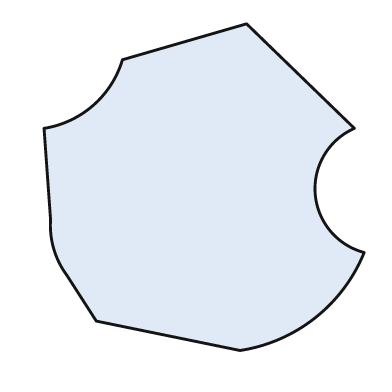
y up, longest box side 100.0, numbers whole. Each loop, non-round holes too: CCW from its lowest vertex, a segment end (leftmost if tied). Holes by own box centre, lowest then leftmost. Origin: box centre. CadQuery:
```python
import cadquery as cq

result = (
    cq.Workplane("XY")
    .moveTo(11.0, -50.0)
    .threePointArc((34.0, -40.0), (49.0, -20.0))
    .threePointArc((34.0, -2.0), (46.0, 18.0))
    .lineTo(13.0, 50.0)
    .lineTo(-25.0, 39.0)
    .threePointArc((-34.0, 25.0), (-49.0, 18.0))
    .lineTo(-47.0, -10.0)
    .threePointArc((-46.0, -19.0), (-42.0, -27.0))
    .lineTo(-33.0, -41.0)
    .close()
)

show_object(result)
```